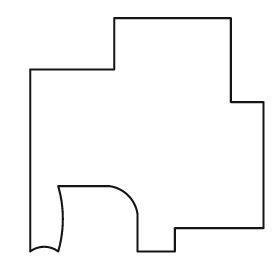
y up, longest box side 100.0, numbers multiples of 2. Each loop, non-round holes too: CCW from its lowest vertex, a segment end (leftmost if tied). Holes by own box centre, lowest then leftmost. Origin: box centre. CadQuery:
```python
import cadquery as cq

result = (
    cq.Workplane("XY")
    .moveTo(-50.0, -50.0)
    .threePointArc((-44.0, -48.0), (-38.0, -50.0))
    .threePointArc((-36.0, -36.0), (-38.0, -22.0))
    .lineTo(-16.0, -22.0)
    .threePointArc((-8.0, -26.0), (-4.0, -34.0))
    .lineTo(-4.0, -50.0)
    .lineTo(12.0, -50.0)
    .lineTo(12.0, -40.0)
    .lineTo(50.0, -40.0)
    .lineTo(50.0, 14.0)
    .lineTo(36.0, 14.0)
    .lineTo(36.0, 50.0)
    .lineTo(-14.0, 50.0)
    .lineTo(-14.0, 28.0)
    .lineTo(-50.0, 28.0)
    .close()
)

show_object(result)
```